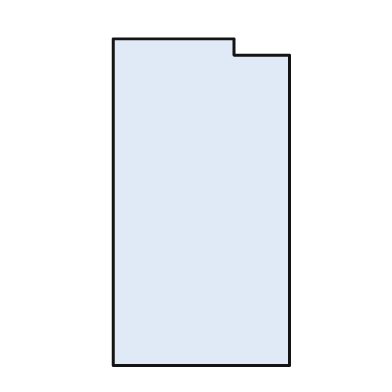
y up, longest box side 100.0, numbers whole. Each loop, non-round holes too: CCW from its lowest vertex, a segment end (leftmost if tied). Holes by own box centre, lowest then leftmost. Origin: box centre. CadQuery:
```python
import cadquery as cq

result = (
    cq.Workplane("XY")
    .moveTo(-27.0, -50.0)
    .lineTo(27.0, -50.0)
    .lineTo(27.0, 45.0)
    .lineTo(10.0, 45.0)
    .lineTo(10.0, 50.0)
    .lineTo(-27.0, 50.0)
    .close()
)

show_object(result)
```